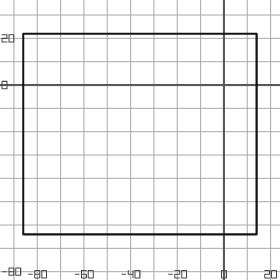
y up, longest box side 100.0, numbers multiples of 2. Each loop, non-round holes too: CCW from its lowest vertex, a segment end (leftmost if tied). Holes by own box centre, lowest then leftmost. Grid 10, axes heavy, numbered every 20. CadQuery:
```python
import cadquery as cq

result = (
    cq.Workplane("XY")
    .moveTo(-86.0, -64.0)
    .lineTo(14.0, -64.0)
    .lineTo(14.0, 22.0)
    .lineTo(-86.0, 22.0)
    .close()
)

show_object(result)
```